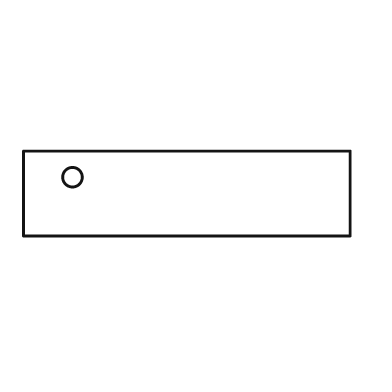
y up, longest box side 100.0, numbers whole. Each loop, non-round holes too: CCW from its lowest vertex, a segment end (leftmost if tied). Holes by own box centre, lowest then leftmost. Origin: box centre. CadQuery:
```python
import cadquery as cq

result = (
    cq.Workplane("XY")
    .moveTo(-50.0, -13.0)
    .lineTo(50.0, -13.0)
    .lineTo(50.0, 13.0)
    .lineTo(-50.0, 13.0)
    .close()
    .moveTo(-35.0, 5.0)
    .circle(3.0)
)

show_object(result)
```